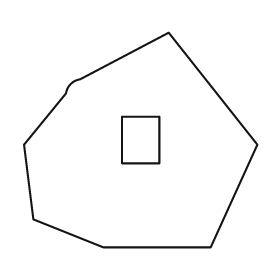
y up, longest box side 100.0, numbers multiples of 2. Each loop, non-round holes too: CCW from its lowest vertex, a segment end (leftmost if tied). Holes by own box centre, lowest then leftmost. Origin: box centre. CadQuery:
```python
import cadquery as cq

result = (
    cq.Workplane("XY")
    .moveTo(-16.0, -46.0)
    .lineTo(30.0, -46.0)
    .lineTo(50.0, -2.0)
    .lineTo(12.0, 46.0)
    .lineTo(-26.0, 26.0)
    .threePointArc((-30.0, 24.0), (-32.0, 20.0))
    .lineTo(-50.0, -2.0)
    .lineTo(-46.0, -34.0)
    .close()
    .moveTo(-8.0, -10.0)
    .lineTo(8.0, -10.0)
    .lineTo(8.0, 10.0)
    .lineTo(-8.0, 10.0)
    .close()
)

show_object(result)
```